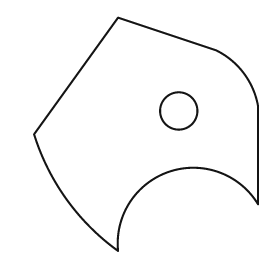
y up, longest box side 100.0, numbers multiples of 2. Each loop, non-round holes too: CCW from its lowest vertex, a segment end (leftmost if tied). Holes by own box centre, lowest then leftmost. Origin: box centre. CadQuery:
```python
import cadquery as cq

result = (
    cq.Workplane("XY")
    .moveTo(-12.0, -50.0)
    .threePointArc((10.0, -16.0), (48.0, -30.0))
    .lineTo(48.0, 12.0)
    .threePointArc((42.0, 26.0), (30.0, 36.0))
    .lineTo(-12.0, 50.0)
    .lineTo(-48.0, 0.0)
    .threePointArc((-34.0, -28.0), (-12.0, -50.0))
    .close()
    .moveTo(14.0, 10.0)
    .circle(8.0)
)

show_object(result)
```